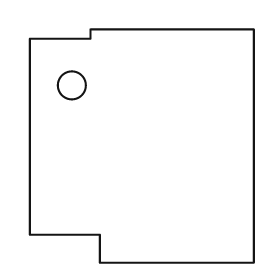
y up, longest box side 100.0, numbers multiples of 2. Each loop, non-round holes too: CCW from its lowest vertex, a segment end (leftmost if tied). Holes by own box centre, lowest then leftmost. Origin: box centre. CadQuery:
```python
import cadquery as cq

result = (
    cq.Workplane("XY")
    .moveTo(-18.0, -50.0)
    .lineTo(48.0, -50.0)
    .lineTo(48.0, 50.0)
    .lineTo(-22.0, 50.0)
    .lineTo(-22.0, 46.0)
    .lineTo(-48.0, 46.0)
    .lineTo(-48.0, -38.0)
    .lineTo(-18.0, -38.0)
    .close()
    .moveTo(-30.0, 26.0)
    .circle(6.0)
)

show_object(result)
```